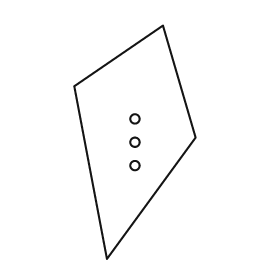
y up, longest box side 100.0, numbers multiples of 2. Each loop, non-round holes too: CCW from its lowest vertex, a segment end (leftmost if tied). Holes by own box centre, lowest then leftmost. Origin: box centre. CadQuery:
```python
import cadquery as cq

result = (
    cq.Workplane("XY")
    .moveTo(-12.0, -50.0)
    .lineTo(26.0, 2.0)
    .lineTo(12.0, 50.0)
    .lineTo(-26.0, 24.0)
    .close()
    .moveTo(0.0, -10.0)
    .circle(2.0)
    .moveTo(0.0, 0.0)
    .circle(2.0)
    .moveTo(0.0, 10.0)
    .circle(2.0)
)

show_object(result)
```